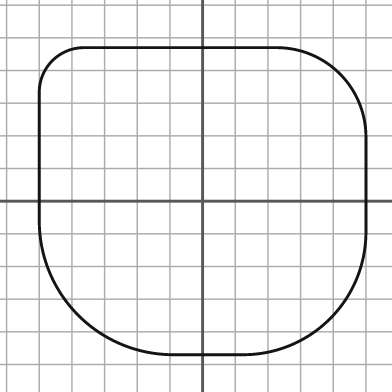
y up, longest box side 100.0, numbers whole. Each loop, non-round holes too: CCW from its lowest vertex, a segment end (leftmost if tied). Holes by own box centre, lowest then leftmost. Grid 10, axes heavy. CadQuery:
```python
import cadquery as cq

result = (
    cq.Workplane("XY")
    .moveTo(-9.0, -47.0)
    .lineTo(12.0, -47.0)
    .threePointArc((39.0, -36.0), (50.0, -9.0))
    .lineTo(50.0, 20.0)
    .threePointArc((42.0, 39.0), (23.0, 47.0))
    .lineTo(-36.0, 47.0)
    .threePointArc((-46.0, 43.0), (-50.0, 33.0))
    .lineTo(-50.0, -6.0)
    .threePointArc((-38.0, -35.0), (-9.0, -47.0))
    .close()
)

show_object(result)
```